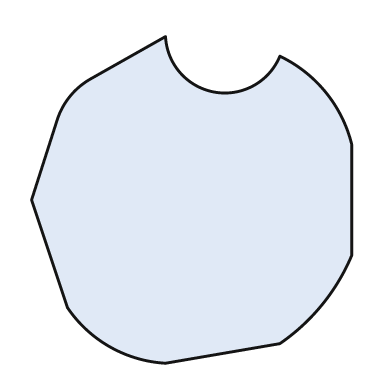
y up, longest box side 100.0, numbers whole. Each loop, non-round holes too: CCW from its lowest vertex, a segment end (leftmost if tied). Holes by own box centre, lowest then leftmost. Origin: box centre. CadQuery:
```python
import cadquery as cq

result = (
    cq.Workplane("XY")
    .moveTo(-8.0, -50.0)
    .lineTo(27.0, -44.0)
    .threePointArc((40.0, -32.0), (49.0, -17.0))
    .lineTo(49.0, 17.0)
    .threePointArc((41.0, 33.0), (27.0, 44.0))
    .threePointArc((7.0, 33.0), (-8.0, 50.0))
    .lineTo(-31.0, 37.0)
    .threePointArc((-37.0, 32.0), (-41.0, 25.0))
    .lineTo(-49.0, 0.0)
    .lineTo(-38.0, -33.0)
    .threePointArc((-25.0, -45.0), (-8.0, -50.0))
    .close()
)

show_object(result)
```